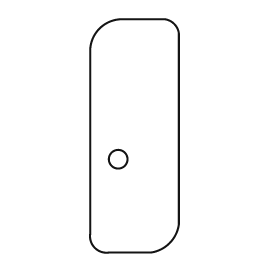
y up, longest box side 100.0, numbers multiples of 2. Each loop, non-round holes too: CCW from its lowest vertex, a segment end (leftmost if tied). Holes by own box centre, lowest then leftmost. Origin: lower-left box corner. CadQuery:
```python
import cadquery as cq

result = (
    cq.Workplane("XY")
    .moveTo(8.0, 0.0)
    .lineTo(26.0, 0.0)
    .threePointArc((34.0, 4.0), (38.0, 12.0))
    .lineTo(38.0, 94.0)
    .threePointArc((36.0, 98.0), (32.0, 100.0))
    .lineTo(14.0, 100.0)
    .threePointArc((4.0, 96.0), (0.0, 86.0))
    .lineTo(0.0, 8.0)
    .threePointArc((2.0, 2.0), (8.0, 0.0))
    .close()
    .moveTo(12.0, 40.0)
    .circle(4.0)
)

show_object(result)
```